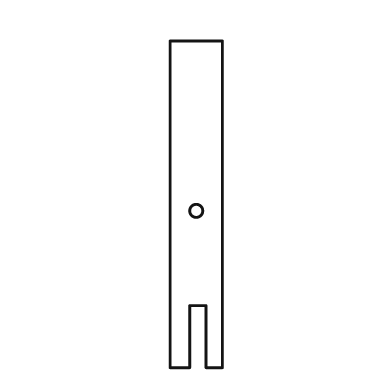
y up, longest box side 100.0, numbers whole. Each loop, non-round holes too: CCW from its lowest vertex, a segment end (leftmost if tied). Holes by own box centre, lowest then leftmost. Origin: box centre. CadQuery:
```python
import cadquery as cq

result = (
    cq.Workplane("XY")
    .moveTo(-8.0, -50.0)
    .lineTo(-2.0, -50.0)
    .lineTo(-2.0, -31.0)
    .lineTo(3.0, -31.0)
    .lineTo(3.0, -50.0)
    .lineTo(8.0, -50.0)
    .lineTo(8.0, 50.0)
    .lineTo(-8.0, 50.0)
    .close()
    .moveTo(0.0, -2.0)
    .circle(2.0)
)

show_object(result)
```